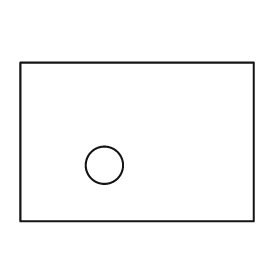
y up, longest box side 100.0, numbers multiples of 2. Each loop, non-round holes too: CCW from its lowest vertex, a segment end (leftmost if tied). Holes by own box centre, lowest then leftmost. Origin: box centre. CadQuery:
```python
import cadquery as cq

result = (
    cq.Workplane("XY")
    .moveTo(-50.0, -34.0)
    .lineTo(50.0, -34.0)
    .lineTo(50.0, 34.0)
    .lineTo(-50.0, 34.0)
    .close()
    .moveTo(-14.0, -10.0)
    .circle(8.0)
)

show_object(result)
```